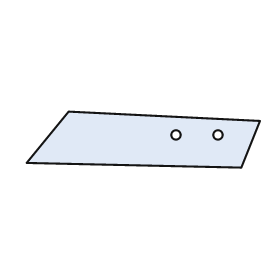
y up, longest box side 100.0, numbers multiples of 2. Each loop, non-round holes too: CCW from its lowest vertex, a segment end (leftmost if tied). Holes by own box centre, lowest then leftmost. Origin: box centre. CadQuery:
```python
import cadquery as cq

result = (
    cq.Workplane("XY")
    .moveTo(42.0, -12.0)
    .lineTo(50.0, 8.0)
    .lineTo(-32.0, 12.0)
    .lineTo(-50.0, -10.0)
    .close()
    .moveTo(14.0, 2.0)
    .circle(2.0)
    .moveTo(32.0, 2.0)
    .circle(2.0)
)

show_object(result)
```